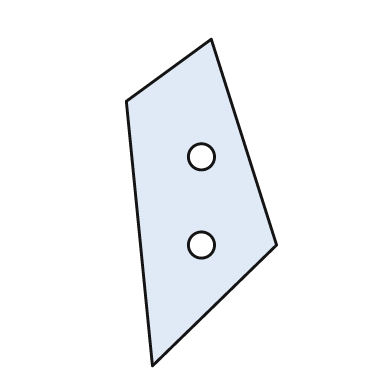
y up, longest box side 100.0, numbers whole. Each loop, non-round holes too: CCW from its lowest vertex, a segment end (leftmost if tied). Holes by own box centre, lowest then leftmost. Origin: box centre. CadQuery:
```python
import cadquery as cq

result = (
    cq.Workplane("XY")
    .moveTo(-15.0, -50.0)
    .lineTo(23.0, -13.0)
    .lineTo(3.0, 50.0)
    .lineTo(-23.0, 31.0)
    .close()
    .moveTo(0.0, -13.0)
    .circle(4.0)
    .moveTo(0.0, 14.0)
    .circle(4.0)
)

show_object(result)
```